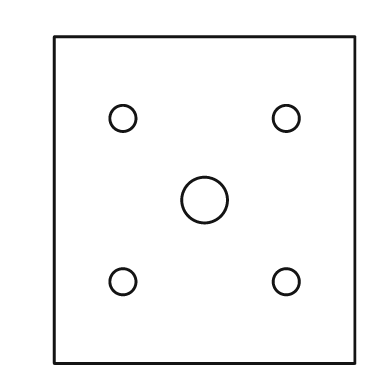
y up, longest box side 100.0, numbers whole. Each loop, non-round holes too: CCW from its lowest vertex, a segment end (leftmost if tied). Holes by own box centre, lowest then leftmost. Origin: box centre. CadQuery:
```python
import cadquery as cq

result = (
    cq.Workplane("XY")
    .moveTo(-46.0, -50.0)
    .lineTo(46.0, -50.0)
    .lineTo(46.0, 50.0)
    .lineTo(-46.0, 50.0)
    .close()
    .moveTo(-25.0, -25.0)
    .circle(4.0)
    .moveTo(25.0, -25.0)
    .circle(4.0)
    .moveTo(0.0, 0.0)
    .circle(7.0)
    .moveTo(-25.0, 25.0)
    .circle(4.0)
    .moveTo(25.0, 25.0)
    .circle(4.0)
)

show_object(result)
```